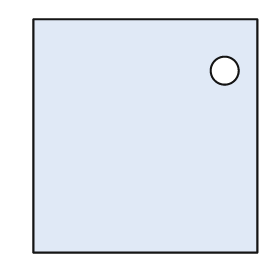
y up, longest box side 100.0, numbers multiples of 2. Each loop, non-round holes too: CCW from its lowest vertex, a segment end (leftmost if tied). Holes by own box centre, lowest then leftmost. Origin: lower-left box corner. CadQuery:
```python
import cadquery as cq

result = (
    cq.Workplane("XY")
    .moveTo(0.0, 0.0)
    .lineTo(96.0, 0.0)
    .lineTo(96.0, 100.0)
    .lineTo(0.0, 100.0)
    .close()
    .moveTo(82.0, 78.0)
    .circle(6.0)
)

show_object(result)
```